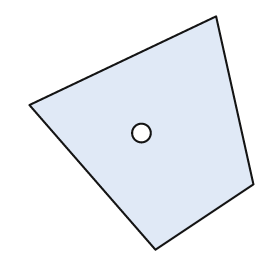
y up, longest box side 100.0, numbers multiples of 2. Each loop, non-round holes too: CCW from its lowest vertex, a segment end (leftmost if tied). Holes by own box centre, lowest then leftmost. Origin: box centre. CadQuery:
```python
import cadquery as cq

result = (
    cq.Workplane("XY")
    .moveTo(6.0, -50.0)
    .lineTo(48.0, -22.0)
    .lineTo(32.0, 50.0)
    .lineTo(-48.0, 12.0)
    .close()
    .moveTo(0.0, 0.0)
    .circle(4.0)
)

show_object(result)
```